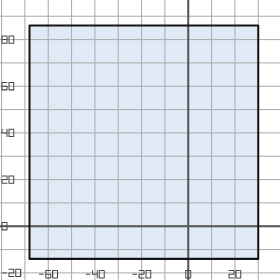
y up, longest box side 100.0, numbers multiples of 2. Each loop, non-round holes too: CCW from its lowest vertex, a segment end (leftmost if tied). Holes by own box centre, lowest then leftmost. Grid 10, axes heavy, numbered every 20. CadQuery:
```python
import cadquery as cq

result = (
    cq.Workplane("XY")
    .moveTo(-68.0, -14.0)
    .lineTo(30.0, -14.0)
    .lineTo(30.0, 86.0)
    .lineTo(-68.0, 86.0)
    .close()
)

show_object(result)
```